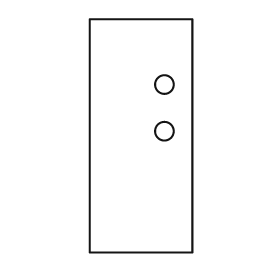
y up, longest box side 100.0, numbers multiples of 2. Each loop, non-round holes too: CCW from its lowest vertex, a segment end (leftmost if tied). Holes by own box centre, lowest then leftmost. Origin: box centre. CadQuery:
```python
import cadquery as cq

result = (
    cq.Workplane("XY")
    .moveTo(-22.0, -50.0)
    .lineTo(22.0, -50.0)
    .lineTo(22.0, 50.0)
    .lineTo(-22.0, 50.0)
    .close()
    .moveTo(10.0, 2.0)
    .circle(4.0)
    .moveTo(10.0, 22.0)
    .circle(4.0)
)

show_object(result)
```